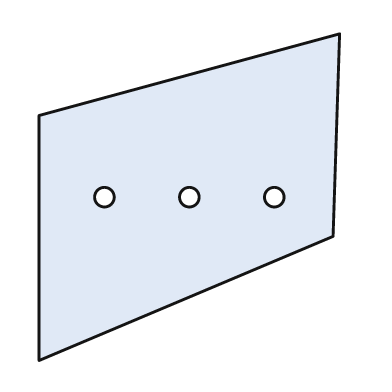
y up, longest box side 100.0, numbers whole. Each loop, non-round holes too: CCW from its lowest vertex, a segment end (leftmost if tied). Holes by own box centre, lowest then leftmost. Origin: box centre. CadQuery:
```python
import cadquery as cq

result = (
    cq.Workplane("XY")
    .moveTo(-46.0, -50.0)
    .lineTo(44.0, -12.0)
    .lineTo(46.0, 50.0)
    .lineTo(-46.0, 25.0)
    .close()
    .moveTo(-26.0, 0.0)
    .circle(3.0)
    .moveTo(0.0, 0.0)
    .circle(3.0)
    .moveTo(26.0, 0.0)
    .circle(3.0)
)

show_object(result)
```